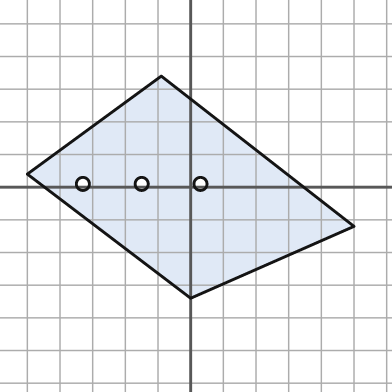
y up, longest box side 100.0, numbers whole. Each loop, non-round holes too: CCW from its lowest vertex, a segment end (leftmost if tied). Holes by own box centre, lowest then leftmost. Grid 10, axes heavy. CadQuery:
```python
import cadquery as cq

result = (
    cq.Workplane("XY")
    .moveTo(0.0, -34.0)
    .lineTo(50.0, -12.0)
    .lineTo(-9.0, 34.0)
    .lineTo(-50.0, 4.0)
    .close()
    .moveTo(-33.0, 1.0)
    .circle(2.0)
    .moveTo(-15.0, 1.0)
    .circle(2.0)
    .moveTo(3.0, 1.0)
    .circle(2.0)
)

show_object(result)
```